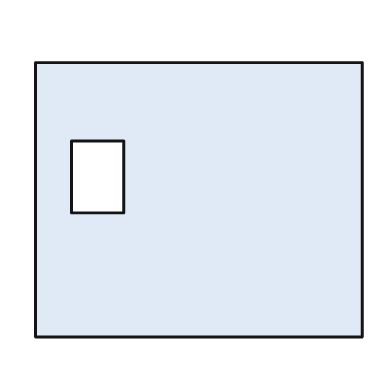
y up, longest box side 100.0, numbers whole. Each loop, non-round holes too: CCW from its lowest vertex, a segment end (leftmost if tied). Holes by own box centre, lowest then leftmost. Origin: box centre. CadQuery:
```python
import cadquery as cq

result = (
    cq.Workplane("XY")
    .moveTo(-50.0, -42.0)
    .lineTo(50.0, -42.0)
    .lineTo(50.0, 42.0)
    .lineTo(-50.0, 42.0)
    .close()
    .moveTo(-39.0, -4.0)
    .lineTo(-23.0, -4.0)
    .lineTo(-23.0, 18.0)
    .lineTo(-39.0, 18.0)
    .close()
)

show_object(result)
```